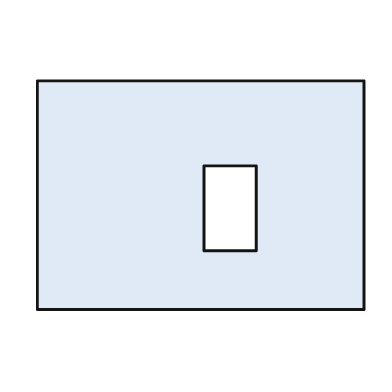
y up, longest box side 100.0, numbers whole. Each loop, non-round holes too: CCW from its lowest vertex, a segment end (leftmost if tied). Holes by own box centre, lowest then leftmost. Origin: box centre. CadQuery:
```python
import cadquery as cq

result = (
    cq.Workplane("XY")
    .moveTo(-50.0, -35.0)
    .lineTo(50.0, -35.0)
    .lineTo(50.0, 35.0)
    .lineTo(-50.0, 35.0)
    .close()
    .moveTo(1.0, -17.0)
    .lineTo(17.0, -17.0)
    .lineTo(17.0, 9.0)
    .lineTo(1.0, 9.0)
    .close()
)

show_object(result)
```